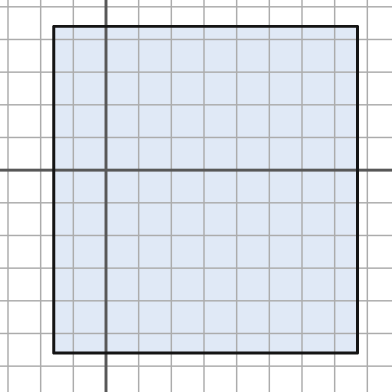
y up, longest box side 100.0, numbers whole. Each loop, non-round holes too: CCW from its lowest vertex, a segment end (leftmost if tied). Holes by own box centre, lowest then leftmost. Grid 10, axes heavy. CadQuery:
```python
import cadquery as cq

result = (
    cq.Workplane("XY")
    .moveTo(-16.0, -56.0)
    .lineTo(77.0, -56.0)
    .lineTo(77.0, 44.0)
    .lineTo(-16.0, 44.0)
    .close()
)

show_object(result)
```